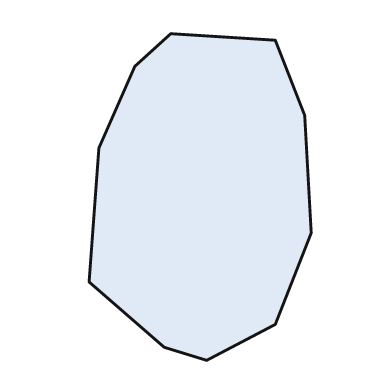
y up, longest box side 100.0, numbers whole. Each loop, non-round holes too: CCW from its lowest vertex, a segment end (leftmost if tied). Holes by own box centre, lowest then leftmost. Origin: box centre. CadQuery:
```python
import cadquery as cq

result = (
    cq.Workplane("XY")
    .moveTo(2.0, -50.0)
    .lineTo(23.0, -39.0)
    .lineTo(34.0, -11.0)
    .lineTo(32.0, 25.0)
    .lineTo(23.0, 48.0)
    .lineTo(-9.0, 50.0)
    .lineTo(-20.0, 40.0)
    .lineTo(-31.0, 15.0)
    .lineTo(-34.0, -26.0)
    .lineTo(-11.0, -46.0)
    .close()
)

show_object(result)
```